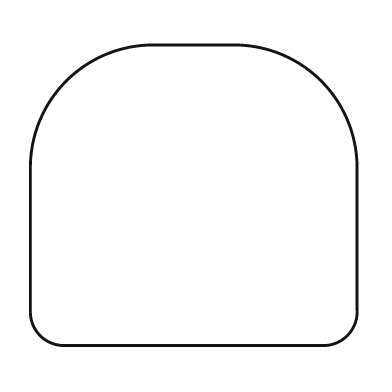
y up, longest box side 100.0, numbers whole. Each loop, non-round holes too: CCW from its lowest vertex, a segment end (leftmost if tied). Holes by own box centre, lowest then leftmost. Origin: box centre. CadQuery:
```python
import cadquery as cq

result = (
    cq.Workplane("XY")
    .moveTo(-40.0, -46.0)
    .lineTo(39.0, -46.0)
    .threePointArc((47.0, -43.0), (50.0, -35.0))
    .lineTo(50.0, 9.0)
    .threePointArc((39.0, 35.0), (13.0, 46.0))
    .lineTo(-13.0, 46.0)
    .threePointArc((-39.0, 35.0), (-50.0, 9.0))
    .lineTo(-50.0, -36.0)
    .threePointArc((-47.0, -43.0), (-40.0, -46.0))
    .close()
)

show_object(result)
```